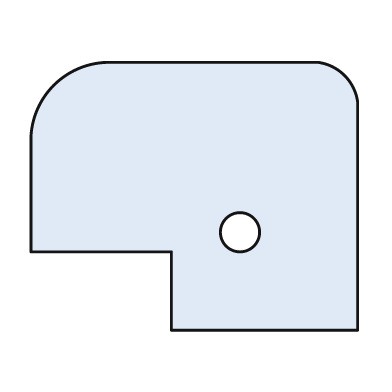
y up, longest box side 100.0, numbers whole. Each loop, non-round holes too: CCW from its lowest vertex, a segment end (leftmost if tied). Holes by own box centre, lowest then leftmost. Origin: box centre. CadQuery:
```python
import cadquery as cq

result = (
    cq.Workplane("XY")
    .moveTo(-7.0, -41.0)
    .lineTo(50.0, -41.0)
    .lineTo(50.0, 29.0)
    .threePointArc((46.0, 37.0), (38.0, 41.0))
    .lineTo(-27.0, 41.0)
    .threePointArc((-43.0, 34.0), (-50.0, 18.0))
    .lineTo(-50.0, -17.0)
    .lineTo(-7.0, -17.0)
    .close()
    .moveTo(14.0, -11.0)
    .circle(6.0)
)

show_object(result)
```